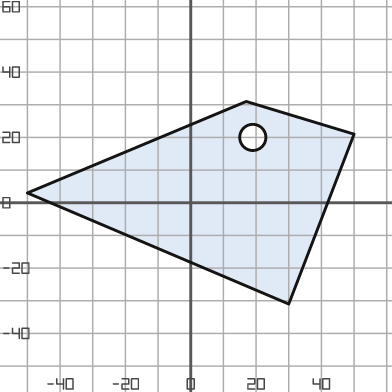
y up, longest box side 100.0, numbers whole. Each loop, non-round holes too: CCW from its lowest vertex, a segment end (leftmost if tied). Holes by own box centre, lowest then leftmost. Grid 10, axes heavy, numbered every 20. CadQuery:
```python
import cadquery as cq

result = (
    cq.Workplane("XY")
    .moveTo(30.0, -31.0)
    .lineTo(50.0, 21.0)
    .lineTo(17.0, 31.0)
    .lineTo(-50.0, 3.0)
    .close()
    .moveTo(19.0, 20.0)
    .circle(4.0)
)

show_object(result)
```